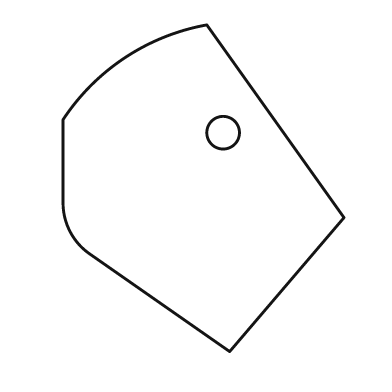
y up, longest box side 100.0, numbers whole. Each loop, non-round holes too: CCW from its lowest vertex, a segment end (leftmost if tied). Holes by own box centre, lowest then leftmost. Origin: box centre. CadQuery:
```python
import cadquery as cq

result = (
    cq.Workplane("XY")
    .moveTo(8.0, -50.0)
    .lineTo(43.0, -9.0)
    .lineTo(1.0, 50.0)
    .threePointArc((-24.0, 40.0), (-43.0, 21.0))
    .lineTo(-43.0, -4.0)
    .threePointArc((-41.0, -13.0), (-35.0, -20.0))
    .close()
    .moveTo(6.0, 17.0)
    .circle(5.0)
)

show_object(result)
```